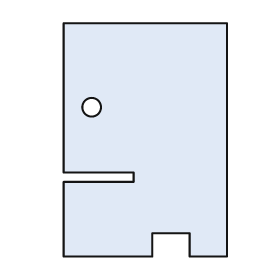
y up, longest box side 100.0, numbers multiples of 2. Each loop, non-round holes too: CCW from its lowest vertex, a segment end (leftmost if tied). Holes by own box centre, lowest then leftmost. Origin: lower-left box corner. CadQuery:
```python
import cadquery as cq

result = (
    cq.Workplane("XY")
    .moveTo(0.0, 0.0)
    .lineTo(38.0, 0.0)
    .lineTo(38.0, 10.0)
    .lineTo(54.0, 10.0)
    .lineTo(54.0, 0.0)
    .lineTo(70.0, 0.0)
    .lineTo(70.0, 100.0)
    .lineTo(0.0, 100.0)
    .lineTo(0.0, 36.0)
    .lineTo(30.0, 36.0)
    .lineTo(30.0, 32.0)
    .lineTo(0.0, 32.0)
    .close()
    .moveTo(12.0, 64.0)
    .circle(4.0)
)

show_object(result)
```